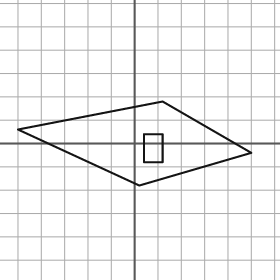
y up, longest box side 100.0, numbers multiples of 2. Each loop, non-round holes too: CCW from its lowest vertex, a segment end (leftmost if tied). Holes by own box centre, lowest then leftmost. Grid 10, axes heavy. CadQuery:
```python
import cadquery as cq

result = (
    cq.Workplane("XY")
    .moveTo(2.0, -18.0)
    .lineTo(50.0, -4.0)
    .lineTo(12.0, 18.0)
    .lineTo(-50.0, 6.0)
    .close()
    .moveTo(4.0, -8.0)
    .lineTo(12.0, -8.0)
    .lineTo(12.0, 4.0)
    .lineTo(4.0, 4.0)
    .close()
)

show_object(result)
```